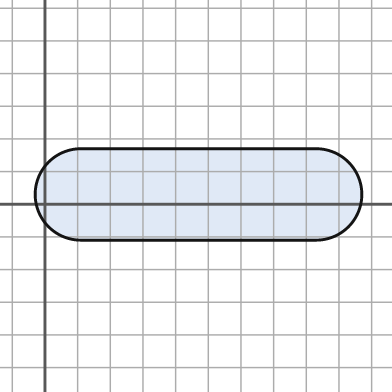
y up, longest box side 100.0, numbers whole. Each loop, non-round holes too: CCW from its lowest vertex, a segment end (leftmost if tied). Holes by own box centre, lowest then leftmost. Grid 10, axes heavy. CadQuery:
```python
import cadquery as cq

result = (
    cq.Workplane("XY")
    .moveTo(11.0, -11.0)
    .lineTo(83.0, -11.0)
    .threePointArc((97.0, 3.0), (83.0, 17.0))
    .lineTo(11.0, 17.0)
    .threePointArc((-3.0, 3.0), (11.0, -11.0))
    .close()
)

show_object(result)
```